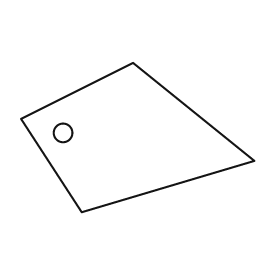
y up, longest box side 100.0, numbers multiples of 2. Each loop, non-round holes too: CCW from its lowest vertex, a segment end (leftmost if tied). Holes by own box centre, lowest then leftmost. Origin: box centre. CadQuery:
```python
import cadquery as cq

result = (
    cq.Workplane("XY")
    .moveTo(-24.0, -32.0)
    .lineTo(50.0, -10.0)
    .lineTo(-2.0, 32.0)
    .lineTo(-50.0, 8.0)
    .close()
    .moveTo(-32.0, 2.0)
    .circle(4.0)
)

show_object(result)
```